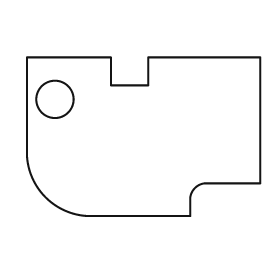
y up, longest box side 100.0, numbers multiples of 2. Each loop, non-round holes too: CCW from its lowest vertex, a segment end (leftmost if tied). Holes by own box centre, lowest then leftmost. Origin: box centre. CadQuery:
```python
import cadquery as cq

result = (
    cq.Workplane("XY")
    .moveTo(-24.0, -34.0)
    .lineTo(20.0, -34.0)
    .lineTo(20.0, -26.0)
    .threePointArc((22.0, -22.0), (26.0, -20.0))
    .lineTo(50.0, -20.0)
    .lineTo(50.0, 34.0)
    .lineTo(2.0, 34.0)
    .lineTo(2.0, 22.0)
    .lineTo(-14.0, 22.0)
    .lineTo(-14.0, 34.0)
    .lineTo(-50.0, 34.0)
    .lineTo(-50.0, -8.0)
    .threePointArc((-42.0, -26.0), (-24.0, -34.0))
    .close()
    .moveTo(-38.0, 16.0)
    .circle(8.0)
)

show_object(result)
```